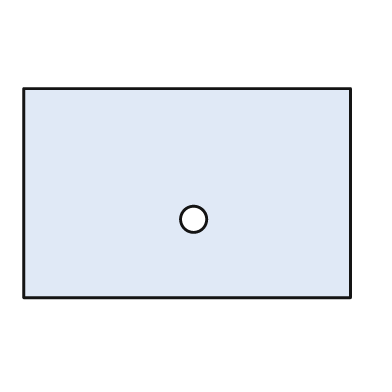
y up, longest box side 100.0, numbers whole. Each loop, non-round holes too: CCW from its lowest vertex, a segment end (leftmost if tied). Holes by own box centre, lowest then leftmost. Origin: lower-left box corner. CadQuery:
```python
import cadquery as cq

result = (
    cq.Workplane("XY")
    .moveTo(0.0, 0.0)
    .lineTo(100.0, 0.0)
    .lineTo(100.0, 64.0)
    .lineTo(0.0, 64.0)
    .close()
    .moveTo(52.0, 24.0)
    .circle(4.0)
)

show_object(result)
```